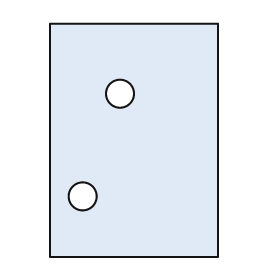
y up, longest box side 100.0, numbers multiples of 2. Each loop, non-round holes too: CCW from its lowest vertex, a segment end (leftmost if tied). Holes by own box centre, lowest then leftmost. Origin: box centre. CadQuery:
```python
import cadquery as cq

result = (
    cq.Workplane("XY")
    .moveTo(-36.0, -50.0)
    .lineTo(36.0, -50.0)
    .lineTo(36.0, 50.0)
    .lineTo(-36.0, 50.0)
    .close()
    .moveTo(-22.0, -24.0)
    .circle(6.0)
    .moveTo(-6.0, 20.0)
    .circle(6.0)
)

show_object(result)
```